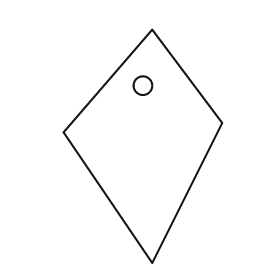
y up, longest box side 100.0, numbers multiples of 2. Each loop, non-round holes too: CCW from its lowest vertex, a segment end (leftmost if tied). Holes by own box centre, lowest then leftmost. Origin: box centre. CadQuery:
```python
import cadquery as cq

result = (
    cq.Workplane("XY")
    .moveTo(4.0, -50.0)
    .lineTo(34.0, 10.0)
    .lineTo(4.0, 50.0)
    .lineTo(-34.0, 6.0)
    .close()
    .moveTo(0.0, 26.0)
    .circle(4.0)
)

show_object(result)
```